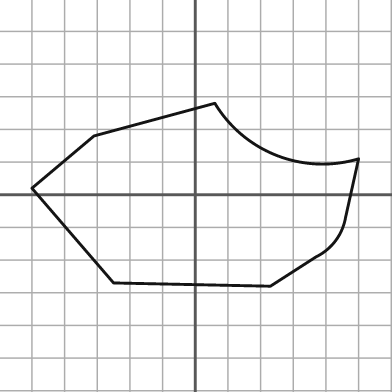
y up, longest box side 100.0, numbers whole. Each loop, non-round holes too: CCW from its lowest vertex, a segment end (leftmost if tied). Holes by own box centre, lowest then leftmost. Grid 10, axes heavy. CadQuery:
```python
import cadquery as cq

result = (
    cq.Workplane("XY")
    .moveTo(23.0, -28.0)
    .lineTo(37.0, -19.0)
    .threePointArc((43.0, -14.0), (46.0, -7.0))
    .lineTo(50.0, 11.0)
    .threePointArc((25.0, 12.0), (6.0, 28.0))
    .lineTo(-31.0, 18.0)
    .lineTo(-50.0, 2.0)
    .lineTo(-25.0, -27.0)
    .close()
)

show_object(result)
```